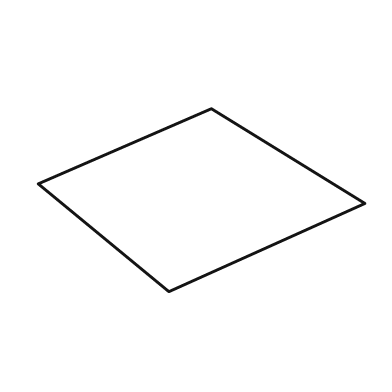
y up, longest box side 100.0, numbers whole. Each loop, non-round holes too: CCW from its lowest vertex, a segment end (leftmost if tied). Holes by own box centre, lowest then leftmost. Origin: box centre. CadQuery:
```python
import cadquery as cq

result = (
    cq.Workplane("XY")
    .moveTo(-10.0, -28.0)
    .lineTo(50.0, -1.0)
    .lineTo(3.0, 28.0)
    .lineTo(-50.0, 5.0)
    .close()
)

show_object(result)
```